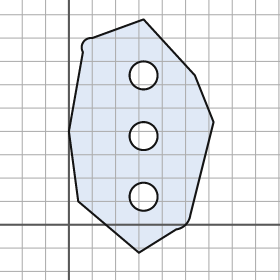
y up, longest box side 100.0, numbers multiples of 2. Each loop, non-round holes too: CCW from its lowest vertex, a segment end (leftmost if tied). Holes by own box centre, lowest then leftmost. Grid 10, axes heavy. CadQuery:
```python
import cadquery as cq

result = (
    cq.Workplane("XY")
    .moveTo(30.0, -12.0)
    .lineTo(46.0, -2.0)
    .threePointArc((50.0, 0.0), (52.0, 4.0))
    .lineTo(62.0, 44.0)
    .lineTo(54.0, 64.0)
    .lineTo(32.0, 88.0)
    .lineTo(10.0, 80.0)
    .threePointArc((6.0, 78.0), (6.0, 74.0))
    .lineTo(0.0, 40.0)
    .lineTo(4.0, 10.0)
    .close()
    .moveTo(32.0, 12.0)
    .circle(6.0)
    .moveTo(32.0, 38.0)
    .circle(6.0)
    .moveTo(32.0, 64.0)
    .circle(6.0)
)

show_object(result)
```